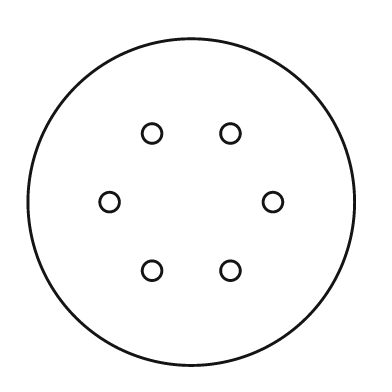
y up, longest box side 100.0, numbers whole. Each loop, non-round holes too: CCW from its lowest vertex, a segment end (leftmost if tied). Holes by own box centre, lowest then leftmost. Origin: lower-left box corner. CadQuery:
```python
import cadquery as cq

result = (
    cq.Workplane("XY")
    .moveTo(50.0, 50.0)
    .circle(50.0)
    .moveTo(38.0, 29.0)
    .circle(3.0)
    .moveTo(62.0, 29.0)
    .circle(3.0)
    .moveTo(25.0, 50.0)
    .circle(3.0)
    .moveTo(75.0, 50.0)
    .circle(3.0)
    .moveTo(38.0, 71.0)
    .circle(3.0)
    .moveTo(62.0, 71.0)
    .circle(3.0)
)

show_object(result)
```